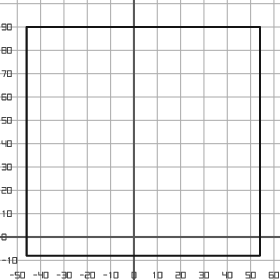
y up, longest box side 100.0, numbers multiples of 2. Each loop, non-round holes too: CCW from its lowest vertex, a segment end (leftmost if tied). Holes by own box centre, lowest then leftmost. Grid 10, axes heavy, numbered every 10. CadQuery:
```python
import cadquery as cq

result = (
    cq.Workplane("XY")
    .moveTo(-46.0, -8.0)
    .lineTo(54.0, -8.0)
    .lineTo(54.0, 90.0)
    .lineTo(-46.0, 90.0)
    .close()
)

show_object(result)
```